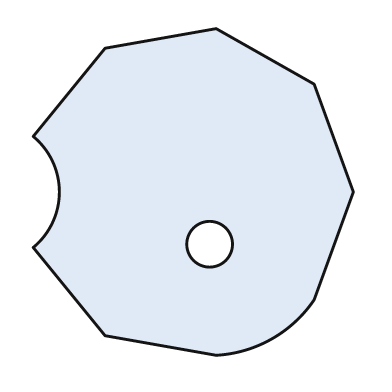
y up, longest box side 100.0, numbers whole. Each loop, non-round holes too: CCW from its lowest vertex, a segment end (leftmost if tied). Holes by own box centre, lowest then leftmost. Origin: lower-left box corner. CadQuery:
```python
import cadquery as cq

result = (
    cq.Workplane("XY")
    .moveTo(56.0, 0.0)
    .threePointArc((73.0, 5.0), (86.0, 17.0))
    .lineTo(98.0, 50.0)
    .lineTo(86.0, 83.0)
    .lineTo(56.0, 100.0)
    .lineTo(22.0, 94.0)
    .lineTo(0.0, 67.0)
    .threePointArc((8.0, 50.0), (0.0, 33.0))
    .lineTo(22.0, 6.0)
    .close()
    .moveTo(54.0, 34.0)
    .circle(7.0)
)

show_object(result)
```